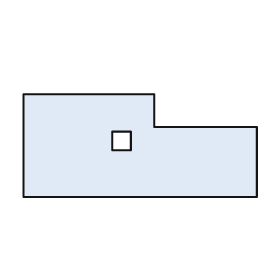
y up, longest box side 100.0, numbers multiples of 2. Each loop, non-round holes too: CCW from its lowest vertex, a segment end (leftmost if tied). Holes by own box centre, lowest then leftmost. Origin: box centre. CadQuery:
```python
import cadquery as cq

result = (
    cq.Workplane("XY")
    .moveTo(-50.0, -22.0)
    .lineTo(50.0, -22.0)
    .lineTo(50.0, 8.0)
    .lineTo(6.0, 8.0)
    .lineTo(6.0, 22.0)
    .lineTo(-50.0, 22.0)
    .close()
    .moveTo(-12.0, -2.0)
    .lineTo(-4.0, -2.0)
    .lineTo(-4.0, 6.0)
    .lineTo(-12.0, 6.0)
    .close()
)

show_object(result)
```